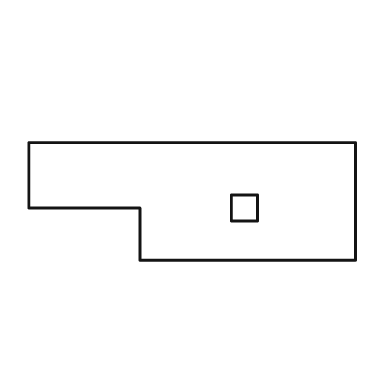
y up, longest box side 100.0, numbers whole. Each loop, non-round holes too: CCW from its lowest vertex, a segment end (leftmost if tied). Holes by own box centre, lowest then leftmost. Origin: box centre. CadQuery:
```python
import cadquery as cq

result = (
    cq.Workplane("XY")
    .moveTo(-16.0, -18.0)
    .lineTo(50.0, -18.0)
    .lineTo(50.0, 18.0)
    .lineTo(-50.0, 18.0)
    .lineTo(-50.0, -2.0)
    .lineTo(-16.0, -2.0)
    .close()
    .moveTo(12.0, -6.0)
    .lineTo(20.0, -6.0)
    .lineTo(20.0, 2.0)
    .lineTo(12.0, 2.0)
    .close()
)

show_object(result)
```